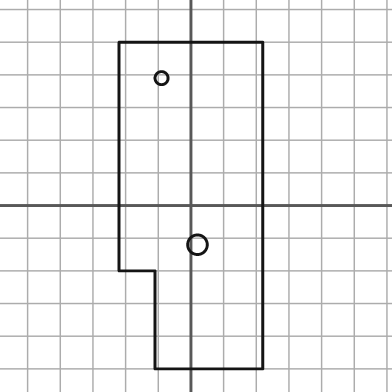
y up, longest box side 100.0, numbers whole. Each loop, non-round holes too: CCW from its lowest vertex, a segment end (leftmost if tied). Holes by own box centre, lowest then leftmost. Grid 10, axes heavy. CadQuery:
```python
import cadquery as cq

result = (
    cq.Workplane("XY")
    .moveTo(-11.0, -50.0)
    .lineTo(22.0, -50.0)
    .lineTo(22.0, 50.0)
    .lineTo(-22.0, 50.0)
    .lineTo(-22.0, -20.0)
    .lineTo(-11.0, -20.0)
    .close()
    .moveTo(2.0, -12.0)
    .circle(3.0)
    .moveTo(-9.0, 39.0)
    .circle(2.0)
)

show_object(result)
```